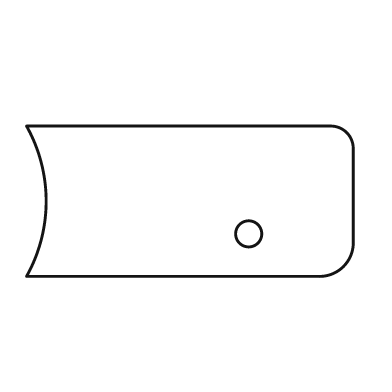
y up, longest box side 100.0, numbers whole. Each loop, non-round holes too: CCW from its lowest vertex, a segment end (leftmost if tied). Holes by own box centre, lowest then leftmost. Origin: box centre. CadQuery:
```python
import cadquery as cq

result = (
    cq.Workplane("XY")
    .moveTo(-50.0, -23.0)
    .lineTo(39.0, -23.0)
    .threePointArc((47.0, -20.0), (50.0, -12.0))
    .lineTo(50.0, 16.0)
    .threePointArc((48.0, 21.0), (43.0, 23.0))
    .lineTo(-50.0, 23.0)
    .threePointArc((-44.0, 0.0), (-50.0, -23.0))
    .close()
    .moveTo(18.0, -10.0)
    .circle(4.0)
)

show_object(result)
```